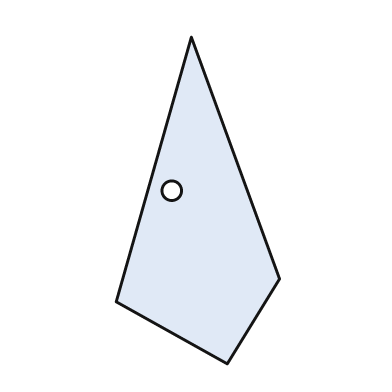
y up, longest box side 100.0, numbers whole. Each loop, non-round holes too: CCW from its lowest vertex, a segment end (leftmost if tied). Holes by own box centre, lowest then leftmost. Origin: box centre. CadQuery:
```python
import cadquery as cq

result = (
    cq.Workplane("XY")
    .moveTo(9.0, -50.0)
    .lineTo(25.0, -24.0)
    .lineTo(-2.0, 50.0)
    .lineTo(-25.0, -31.0)
    .close()
    .moveTo(-8.0, 3.0)
    .circle(3.0)
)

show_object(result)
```